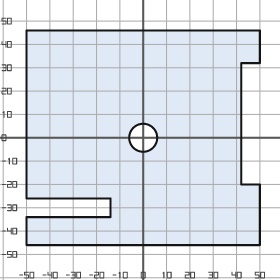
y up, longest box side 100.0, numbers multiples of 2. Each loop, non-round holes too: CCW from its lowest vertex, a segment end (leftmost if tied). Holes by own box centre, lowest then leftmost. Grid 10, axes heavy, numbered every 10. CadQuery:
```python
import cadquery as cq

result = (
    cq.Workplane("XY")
    .moveTo(-50.0, -46.0)
    .lineTo(50.0, -46.0)
    .lineTo(50.0, -20.0)
    .lineTo(42.0, -20.0)
    .lineTo(42.0, 32.0)
    .lineTo(50.0, 32.0)
    .lineTo(50.0, 46.0)
    .lineTo(-50.0, 46.0)
    .lineTo(-50.0, -26.0)
    .lineTo(-14.0, -26.0)
    .lineTo(-14.0, -34.0)
    .lineTo(-50.0, -34.0)
    .close()
    .moveTo(0.0, 0.0)
    .circle(6.0)
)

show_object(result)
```